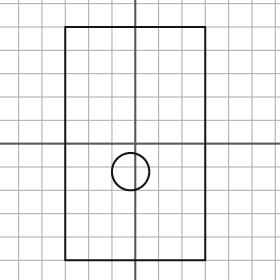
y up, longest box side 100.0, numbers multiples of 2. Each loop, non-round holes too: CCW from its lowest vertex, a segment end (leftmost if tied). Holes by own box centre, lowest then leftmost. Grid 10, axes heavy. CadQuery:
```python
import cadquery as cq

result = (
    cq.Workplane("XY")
    .moveTo(-30.0, -50.0)
    .lineTo(30.0, -50.0)
    .lineTo(30.0, 50.0)
    .lineTo(-30.0, 50.0)
    .close()
    .moveTo(-2.0, -12.0)
    .circle(8.0)
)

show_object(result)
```